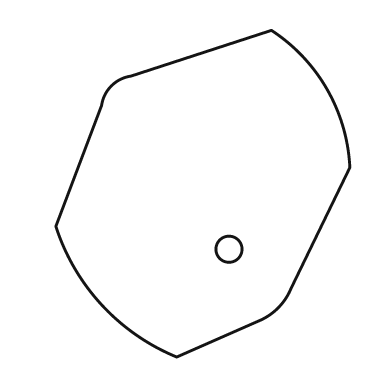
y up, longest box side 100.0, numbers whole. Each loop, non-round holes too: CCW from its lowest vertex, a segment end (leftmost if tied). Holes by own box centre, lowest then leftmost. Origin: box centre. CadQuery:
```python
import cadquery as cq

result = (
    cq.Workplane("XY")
    .moveTo(-8.0, -50.0)
    .lineTo(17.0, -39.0)
    .threePointArc((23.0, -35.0), (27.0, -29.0))
    .lineTo(45.0, 8.0)
    .threePointArc((38.0, 32.0), (21.0, 50.0))
    .lineTo(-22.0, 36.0)
    .threePointArc((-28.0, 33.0), (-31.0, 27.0))
    .lineTo(-45.0, -10.0)
    .threePointArc((-31.0, -34.0), (-8.0, -50.0))
    .close()
    .moveTo(8.0, -17.0)
    .circle(4.0)
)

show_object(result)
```